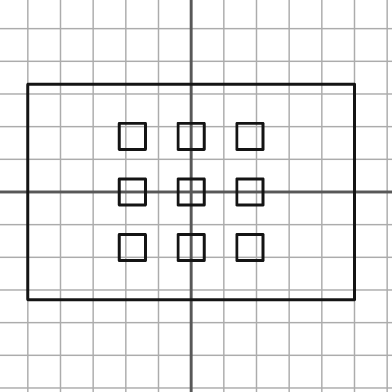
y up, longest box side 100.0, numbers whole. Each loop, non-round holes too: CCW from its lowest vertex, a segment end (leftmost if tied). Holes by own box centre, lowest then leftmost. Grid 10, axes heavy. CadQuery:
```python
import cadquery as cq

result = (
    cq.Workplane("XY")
    .moveTo(-50.0, -33.0)
    .lineTo(50.0, -33.0)
    .lineTo(50.0, 33.0)
    .lineTo(-50.0, 33.0)
    .close()
    .moveTo(-22.0, -21.0)
    .lineTo(-14.0, -21.0)
    .lineTo(-14.0, -13.0)
    .lineTo(-22.0, -13.0)
    .close()
    .moveTo(-4.0, -21.0)
    .lineTo(4.0, -21.0)
    .lineTo(4.0, -13.0)
    .lineTo(-4.0, -13.0)
    .close()
    .moveTo(14.0, -21.0)
    .lineTo(22.0, -21.0)
    .lineTo(22.0, -13.0)
    .lineTo(14.0, -13.0)
    .close()
    .moveTo(-22.0, -4.0)
    .lineTo(-14.0, -4.0)
    .lineTo(-14.0, 4.0)
    .lineTo(-22.0, 4.0)
    .close()
    .moveTo(-4.0, -4.0)
    .lineTo(4.0, -4.0)
    .lineTo(4.0, 4.0)
    .lineTo(-4.0, 4.0)
    .close()
    .moveTo(14.0, -4.0)
    .lineTo(22.0, -4.0)
    .lineTo(22.0, 4.0)
    .lineTo(14.0, 4.0)
    .close()
    .moveTo(-22.0, 13.0)
    .lineTo(-14.0, 13.0)
    .lineTo(-14.0, 21.0)
    .lineTo(-22.0, 21.0)
    .close()
    .moveTo(-4.0, 13.0)
    .lineTo(4.0, 13.0)
    .lineTo(4.0, 21.0)
    .lineTo(-4.0, 21.0)
    .close()
    .moveTo(14.0, 13.0)
    .lineTo(22.0, 13.0)
    .lineTo(22.0, 21.0)
    .lineTo(14.0, 21.0)
    .close()
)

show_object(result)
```